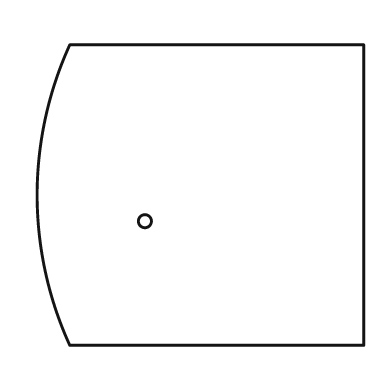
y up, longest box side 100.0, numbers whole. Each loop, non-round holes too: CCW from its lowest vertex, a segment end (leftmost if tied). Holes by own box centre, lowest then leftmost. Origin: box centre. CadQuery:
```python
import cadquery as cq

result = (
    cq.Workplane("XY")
    .moveTo(-40.0, -46.0)
    .lineTo(50.0, -46.0)
    .lineTo(50.0, 46.0)
    .lineTo(-40.0, 46.0)
    .threePointArc((-50.0, 0.0), (-40.0, -46.0))
    .close()
    .moveTo(-17.0, -8.0)
    .circle(2.0)
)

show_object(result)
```